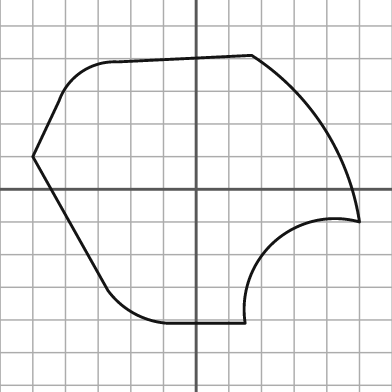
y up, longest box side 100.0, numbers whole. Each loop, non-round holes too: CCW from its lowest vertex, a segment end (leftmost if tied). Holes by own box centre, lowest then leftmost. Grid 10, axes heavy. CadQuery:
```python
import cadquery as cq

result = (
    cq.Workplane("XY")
    .moveTo(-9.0, -41.0)
    .lineTo(15.0, -41.0)
    .threePointArc((24.0, -16.0), (50.0, -10.0))
    .threePointArc((39.0, 19.0), (17.0, 41.0))
    .lineTo(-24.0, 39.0)
    .threePointArc((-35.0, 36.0), (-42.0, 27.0))
    .lineTo(-50.0, 10.0)
    .lineTo(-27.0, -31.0)
    .threePointArc((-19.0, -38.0), (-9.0, -41.0))
    .close()
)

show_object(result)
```